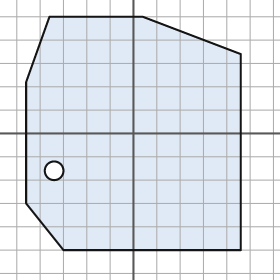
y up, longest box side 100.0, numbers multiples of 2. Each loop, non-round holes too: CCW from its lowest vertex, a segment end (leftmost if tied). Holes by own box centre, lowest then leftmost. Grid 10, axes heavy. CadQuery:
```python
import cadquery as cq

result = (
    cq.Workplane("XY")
    .moveTo(-30.0, -50.0)
    .lineTo(46.0, -50.0)
    .lineTo(46.0, 34.0)
    .lineTo(4.0, 50.0)
    .lineTo(-36.0, 50.0)
    .lineTo(-46.0, 22.0)
    .lineTo(-46.0, -30.0)
    .close()
    .moveTo(-34.0, -16.0)
    .circle(4.0)
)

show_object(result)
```